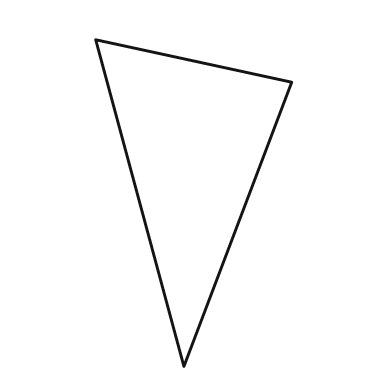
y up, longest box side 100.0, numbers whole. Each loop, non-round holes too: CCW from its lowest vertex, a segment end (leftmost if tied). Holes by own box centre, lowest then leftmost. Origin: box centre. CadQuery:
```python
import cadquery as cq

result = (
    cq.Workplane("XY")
    .moveTo(-3.0, -50.0)
    .lineTo(30.0, 37.0)
    .lineTo(-30.0, 50.0)
    .close()
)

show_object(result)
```